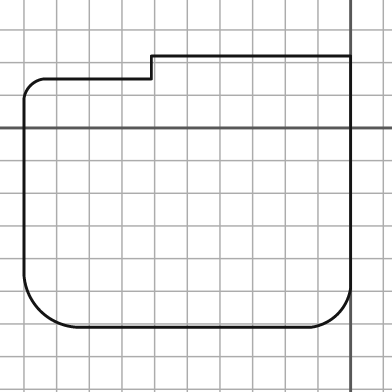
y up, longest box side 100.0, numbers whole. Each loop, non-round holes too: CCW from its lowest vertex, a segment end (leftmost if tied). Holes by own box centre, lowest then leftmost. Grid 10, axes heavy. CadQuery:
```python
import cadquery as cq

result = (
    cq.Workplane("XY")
    .moveTo(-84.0, -61.0)
    .lineTo(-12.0, -61.0)
    .threePointArc((-4.0, -57.0), (0.0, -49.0))
    .lineTo(0.0, 22.0)
    .lineTo(-61.0, 22.0)
    .lineTo(-61.0, 15.0)
    .lineTo(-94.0, 15.0)
    .threePointArc((-98.0, 13.0), (-100.0, 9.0))
    .lineTo(-100.0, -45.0)
    .threePointArc((-95.0, -56.0), (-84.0, -61.0))
    .close()
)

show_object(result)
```